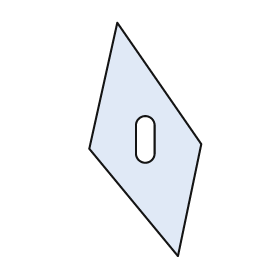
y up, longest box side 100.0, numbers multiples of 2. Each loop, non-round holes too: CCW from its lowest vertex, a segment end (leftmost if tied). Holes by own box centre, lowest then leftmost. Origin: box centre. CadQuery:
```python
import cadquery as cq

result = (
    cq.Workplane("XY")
    .moveTo(14.0, -50.0)
    .lineTo(24.0, -2.0)
    .lineTo(-12.0, 50.0)
    .lineTo(-24.0, -4.0)
    .close()
    .moveTo(-4.0, -6.0)
    .threePointArc((0.0, -10.0), (4.0, -6.0))
    .lineTo(4.0, 6.0)
    .threePointArc((0.0, 10.0), (-4.0, 6.0))
    .close()
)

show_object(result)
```